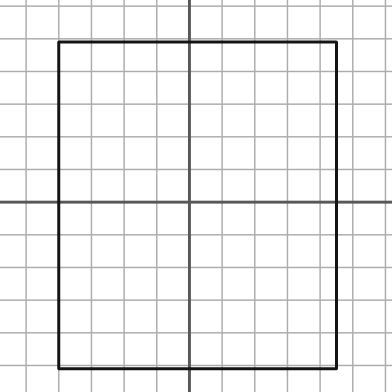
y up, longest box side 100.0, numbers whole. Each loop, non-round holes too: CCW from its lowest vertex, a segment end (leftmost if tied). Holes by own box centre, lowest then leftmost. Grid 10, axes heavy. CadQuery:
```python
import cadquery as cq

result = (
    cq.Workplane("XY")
    .moveTo(-40.0, -51.0)
    .lineTo(45.0, -51.0)
    .lineTo(45.0, 49.0)
    .lineTo(-40.0, 49.0)
    .close()
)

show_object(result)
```